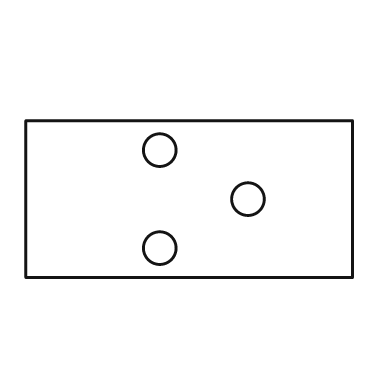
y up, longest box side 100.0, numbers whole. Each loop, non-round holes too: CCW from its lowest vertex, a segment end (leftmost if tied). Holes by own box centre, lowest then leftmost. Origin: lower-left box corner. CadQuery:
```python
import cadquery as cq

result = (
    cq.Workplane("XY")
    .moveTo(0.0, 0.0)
    .lineTo(100.0, 0.0)
    .lineTo(100.0, 48.0)
    .lineTo(0.0, 48.0)
    .close()
    .moveTo(41.0, 9.0)
    .circle(5.0)
    .moveTo(68.0, 24.0)
    .circle(5.0)
    .moveTo(41.0, 39.0)
    .circle(5.0)
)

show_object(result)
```